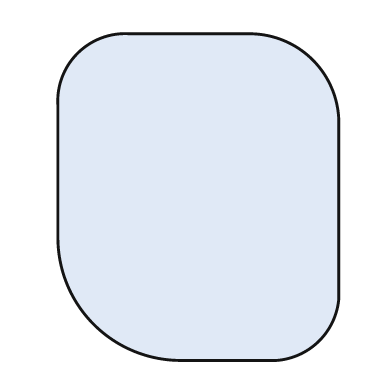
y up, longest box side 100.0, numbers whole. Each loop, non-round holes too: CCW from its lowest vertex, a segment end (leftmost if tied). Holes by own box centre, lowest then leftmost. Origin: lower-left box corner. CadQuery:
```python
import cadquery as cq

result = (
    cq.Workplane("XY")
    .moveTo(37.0, 0.0)
    .lineTo(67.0, 0.0)
    .threePointArc((80.0, 6.0), (86.0, 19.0))
    .lineTo(86.0, 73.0)
    .threePointArc((78.0, 92.0), (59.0, 100.0))
    .lineTo(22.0, 100.0)
    .threePointArc((6.0, 94.0), (0.0, 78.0))
    .lineTo(0.0, 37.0)
    .threePointArc((11.0, 11.0), (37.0, 0.0))
    .close()
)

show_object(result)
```